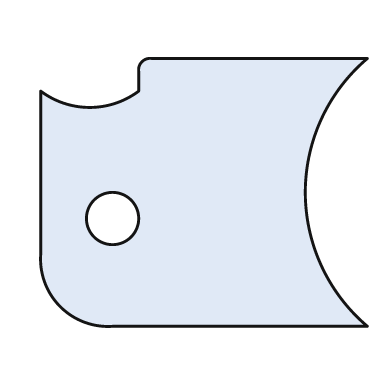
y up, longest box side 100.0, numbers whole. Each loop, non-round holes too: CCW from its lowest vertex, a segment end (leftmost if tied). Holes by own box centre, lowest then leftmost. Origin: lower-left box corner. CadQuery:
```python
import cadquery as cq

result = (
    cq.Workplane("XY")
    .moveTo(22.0, 0.0)
    .lineTo(100.0, 0.0)
    .threePointArc((81.0, 41.0), (100.0, 82.0))
    .lineTo(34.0, 82.0)
    .threePointArc((31.0, 81.0), (30.0, 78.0))
    .lineTo(30.0, 72.0)
    .threePointArc((15.0, 67.0), (0.0, 72.0))
    .lineTo(0.0, 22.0)
    .threePointArc((6.0, 6.0), (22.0, 0.0))
    .close()
    .moveTo(22.0, 33.0)
    .circle(8.0)
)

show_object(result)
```